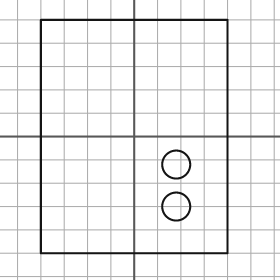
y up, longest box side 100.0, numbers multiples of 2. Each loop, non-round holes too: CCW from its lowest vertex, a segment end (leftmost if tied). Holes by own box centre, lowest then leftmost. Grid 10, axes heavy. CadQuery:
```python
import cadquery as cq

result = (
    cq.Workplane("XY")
    .moveTo(-40.0, -50.0)
    .lineTo(40.0, -50.0)
    .lineTo(40.0, 50.0)
    .lineTo(-40.0, 50.0)
    .close()
    .moveTo(18.0, -30.0)
    .circle(6.0)
    .moveTo(18.0, -12.0)
    .circle(6.0)
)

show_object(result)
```